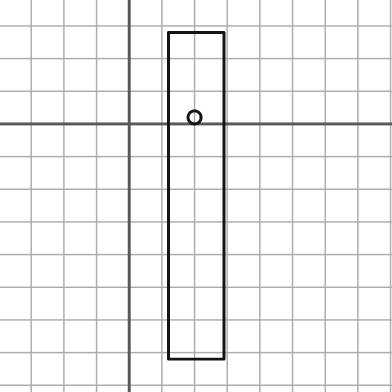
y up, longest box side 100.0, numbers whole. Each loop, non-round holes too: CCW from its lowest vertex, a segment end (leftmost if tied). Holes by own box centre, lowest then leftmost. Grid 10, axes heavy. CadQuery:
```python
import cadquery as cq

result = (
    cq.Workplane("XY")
    .moveTo(12.0, -72.0)
    .lineTo(29.0, -72.0)
    .lineTo(29.0, 28.0)
    .lineTo(12.0, 28.0)
    .close()
    .moveTo(20.0, 2.0)
    .circle(2.0)
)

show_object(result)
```